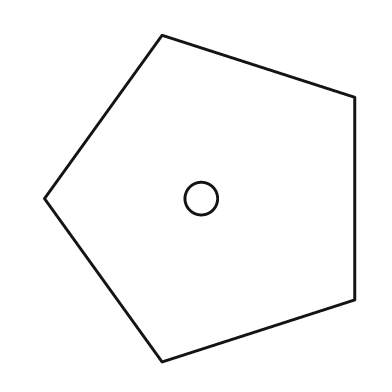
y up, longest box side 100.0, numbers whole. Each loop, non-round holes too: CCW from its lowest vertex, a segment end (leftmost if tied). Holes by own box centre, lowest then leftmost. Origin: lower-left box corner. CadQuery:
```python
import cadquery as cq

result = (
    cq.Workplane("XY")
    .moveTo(36.0, 0.0)
    .lineTo(95.0, 19.0)
    .lineTo(95.0, 81.0)
    .lineTo(36.0, 100.0)
    .lineTo(0.0, 50.0)
    .close()
    .moveTo(48.0, 50.0)
    .circle(5.0)
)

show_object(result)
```